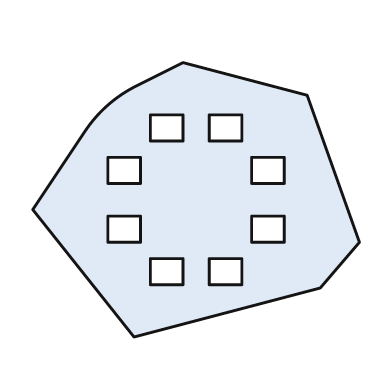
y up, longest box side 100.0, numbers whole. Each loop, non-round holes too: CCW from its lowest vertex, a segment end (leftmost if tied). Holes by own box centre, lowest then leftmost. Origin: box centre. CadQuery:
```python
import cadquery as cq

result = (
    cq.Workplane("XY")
    .moveTo(-19.0, -42.0)
    .lineTo(38.0, -27.0)
    .lineTo(50.0, -13.0)
    .lineTo(34.0, 32.0)
    .lineTo(-4.0, 42.0)
    .lineTo(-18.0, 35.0)
    .threePointArc((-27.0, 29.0), (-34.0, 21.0))
    .lineTo(-50.0, -3.0)
    .close()
    .moveTo(-14.0, -26.0)
    .lineTo(-4.0, -26.0)
    .lineTo(-4.0, -18.0)
    .lineTo(-14.0, -18.0)
    .close()
    .moveTo(4.0, -26.0)
    .lineTo(14.0, -26.0)
    .lineTo(14.0, -18.0)
    .lineTo(4.0, -18.0)
    .close()
    .moveTo(-27.0, -13.0)
    .lineTo(-17.0, -13.0)
    .lineTo(-17.0, -5.0)
    .lineTo(-27.0, -5.0)
    .close()
    .moveTo(17.0, -13.0)
    .lineTo(27.0, -13.0)
    .lineTo(27.0, -5.0)
    .lineTo(17.0, -5.0)
    .close()
    .moveTo(-27.0, 5.0)
    .lineTo(-17.0, 5.0)
    .lineTo(-17.0, 13.0)
    .lineTo(-27.0, 13.0)
    .close()
    .moveTo(17.0, 5.0)
    .lineTo(27.0, 5.0)
    .lineTo(27.0, 13.0)
    .lineTo(17.0, 13.0)
    .close()
    .moveTo(-14.0, 18.0)
    .lineTo(-4.0, 18.0)
    .lineTo(-4.0, 26.0)
    .lineTo(-14.0, 26.0)
    .close()
    .moveTo(4.0, 18.0)
    .lineTo(14.0, 18.0)
    .lineTo(14.0, 26.0)
    .lineTo(4.0, 26.0)
    .close()
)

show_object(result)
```